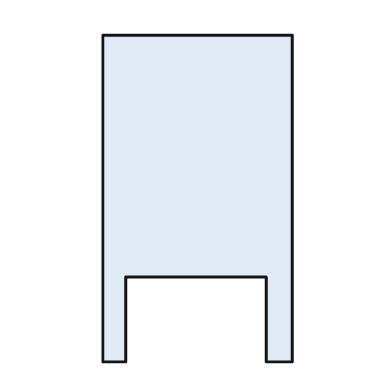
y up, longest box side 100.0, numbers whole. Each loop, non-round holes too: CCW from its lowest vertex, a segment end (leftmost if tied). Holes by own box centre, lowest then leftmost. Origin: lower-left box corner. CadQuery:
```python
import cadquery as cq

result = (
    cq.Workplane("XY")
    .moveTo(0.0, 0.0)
    .lineTo(7.0, 0.0)
    .lineTo(7.0, 26.0)
    .lineTo(50.0, 26.0)
    .lineTo(50.0, 0.0)
    .lineTo(58.0, 0.0)
    .lineTo(58.0, 100.0)
    .lineTo(0.0, 100.0)
    .close()
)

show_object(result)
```